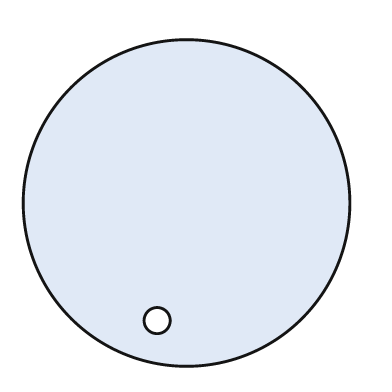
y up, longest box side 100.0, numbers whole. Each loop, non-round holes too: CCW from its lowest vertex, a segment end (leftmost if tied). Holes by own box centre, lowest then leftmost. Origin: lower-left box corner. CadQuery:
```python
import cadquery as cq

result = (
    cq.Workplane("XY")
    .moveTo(50.0, 50.0)
    .circle(50.0)
    .moveTo(41.0, 14.0)
    .circle(4.0)
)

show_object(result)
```